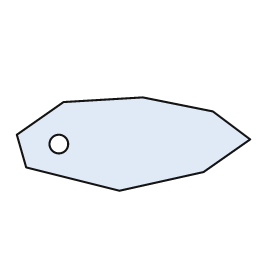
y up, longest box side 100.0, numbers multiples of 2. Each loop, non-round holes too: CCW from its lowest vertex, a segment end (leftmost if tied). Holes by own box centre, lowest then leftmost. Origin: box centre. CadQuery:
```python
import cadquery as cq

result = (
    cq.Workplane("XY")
    .moveTo(-6.0, -20.0)
    .lineTo(30.0, -12.0)
    .lineTo(50.0, 2.0)
    .lineTo(34.0, 14.0)
    .lineTo(4.0, 20.0)
    .lineTo(-30.0, 18.0)
    .lineTo(-50.0, 4.0)
    .lineTo(-46.0, -10.0)
    .close()
    .moveTo(-32.0, 0.0)
    .circle(4.0)
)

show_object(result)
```